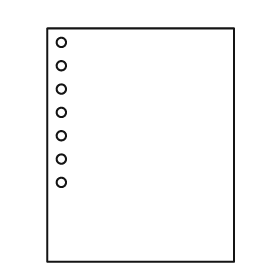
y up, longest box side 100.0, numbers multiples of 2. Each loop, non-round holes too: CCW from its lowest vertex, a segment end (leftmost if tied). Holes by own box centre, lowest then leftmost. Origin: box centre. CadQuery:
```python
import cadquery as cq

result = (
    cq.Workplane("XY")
    .moveTo(-40.0, -50.0)
    .lineTo(40.0, -50.0)
    .lineTo(40.0, 50.0)
    .lineTo(-40.0, 50.0)
    .close()
    .moveTo(-34.0, -16.0)
    .circle(2.0)
    .moveTo(-34.0, -6.0)
    .circle(2.0)
    .moveTo(-34.0, 4.0)
    .circle(2.0)
    .moveTo(-34.0, 14.0)
    .circle(2.0)
    .moveTo(-34.0, 24.0)
    .circle(2.0)
    .moveTo(-34.0, 34.0)
    .circle(2.0)
    .moveTo(-34.0, 44.0)
    .circle(2.0)
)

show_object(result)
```